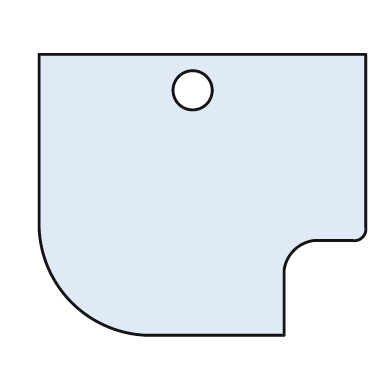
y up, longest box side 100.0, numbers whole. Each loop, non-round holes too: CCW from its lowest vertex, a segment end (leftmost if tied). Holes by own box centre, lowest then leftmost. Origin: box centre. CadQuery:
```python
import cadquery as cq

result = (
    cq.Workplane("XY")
    .moveTo(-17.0, -43.0)
    .lineTo(25.0, -43.0)
    .lineTo(25.0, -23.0)
    .threePointArc((28.0, -17.0), (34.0, -14.0))
    .lineTo(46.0, -14.0)
    .threePointArc((49.0, -13.0), (50.0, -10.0))
    .lineTo(50.0, 43.0)
    .lineTo(-50.0, 43.0)
    .lineTo(-50.0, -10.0)
    .threePointArc((-40.0, -33.0), (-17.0, -43.0))
    .close()
    .moveTo(-3.0, 32.0)
    .circle(6.0)
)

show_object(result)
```